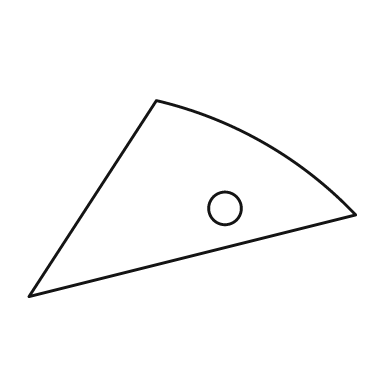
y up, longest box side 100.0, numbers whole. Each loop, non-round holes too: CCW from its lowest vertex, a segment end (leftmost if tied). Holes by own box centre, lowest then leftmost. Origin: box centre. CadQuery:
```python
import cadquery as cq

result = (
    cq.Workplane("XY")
    .moveTo(-50.0, -30.0)
    .lineTo(50.0, -5.0)
    .threePointArc((22.0, 17.0), (-11.0, 30.0))
    .close()
    .moveTo(10.0, -3.0)
    .circle(5.0)
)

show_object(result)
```